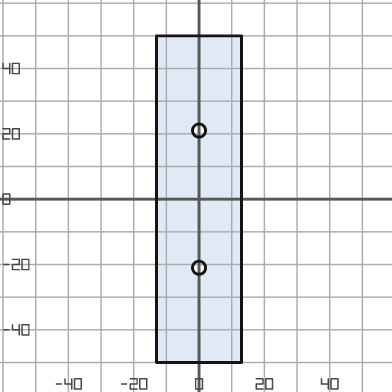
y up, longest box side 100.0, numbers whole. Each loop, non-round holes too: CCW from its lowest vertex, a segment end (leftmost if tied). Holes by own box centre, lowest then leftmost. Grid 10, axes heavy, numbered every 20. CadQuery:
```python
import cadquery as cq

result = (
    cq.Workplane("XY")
    .moveTo(-13.0, -50.0)
    .lineTo(13.0, -50.0)
    .lineTo(13.0, 50.0)
    .lineTo(-13.0, 50.0)
    .close()
    .moveTo(0.0, -21.0)
    .circle(2.0)
    .moveTo(0.0, 21.0)
    .circle(2.0)
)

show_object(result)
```